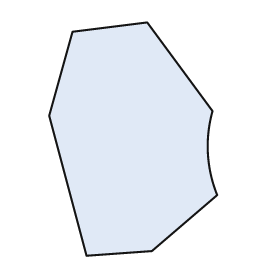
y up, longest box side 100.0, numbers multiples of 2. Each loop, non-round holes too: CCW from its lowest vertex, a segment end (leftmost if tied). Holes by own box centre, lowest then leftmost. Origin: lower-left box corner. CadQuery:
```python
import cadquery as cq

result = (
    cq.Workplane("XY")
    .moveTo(16.0, 0.0)
    .lineTo(44.0, 2.0)
    .lineTo(72.0, 26.0)
    .threePointArc((68.0, 44.0), (70.0, 62.0))
    .lineTo(42.0, 100.0)
    .lineTo(10.0, 96.0)
    .lineTo(0.0, 60.0)
    .close()
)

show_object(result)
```